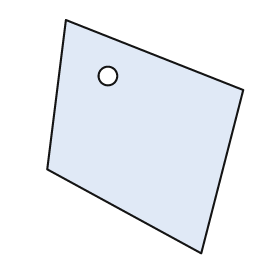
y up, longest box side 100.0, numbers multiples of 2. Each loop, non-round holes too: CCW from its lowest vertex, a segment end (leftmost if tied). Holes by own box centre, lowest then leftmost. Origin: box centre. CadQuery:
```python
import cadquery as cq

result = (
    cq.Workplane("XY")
    .moveTo(24.0, -50.0)
    .lineTo(42.0, 20.0)
    .lineTo(-34.0, 50.0)
    .lineTo(-42.0, -14.0)
    .close()
    .moveTo(-16.0, 26.0)
    .circle(4.0)
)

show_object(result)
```